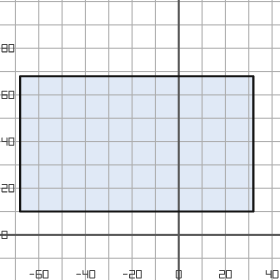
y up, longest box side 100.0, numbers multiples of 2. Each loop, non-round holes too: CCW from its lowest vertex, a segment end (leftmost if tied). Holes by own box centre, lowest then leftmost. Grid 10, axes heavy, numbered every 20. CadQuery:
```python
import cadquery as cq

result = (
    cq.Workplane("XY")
    .moveTo(-68.0, 10.0)
    .lineTo(32.0, 10.0)
    .lineTo(32.0, 68.0)
    .lineTo(-68.0, 68.0)
    .close()
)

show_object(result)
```